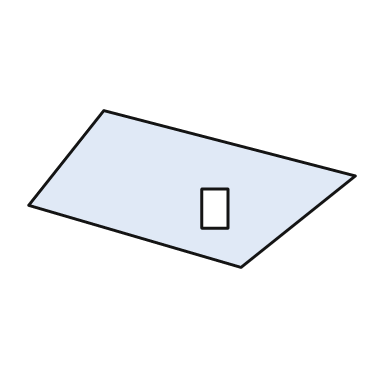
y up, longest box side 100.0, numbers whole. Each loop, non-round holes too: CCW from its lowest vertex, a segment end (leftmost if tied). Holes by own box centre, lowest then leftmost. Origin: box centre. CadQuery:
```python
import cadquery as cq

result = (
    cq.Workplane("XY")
    .moveTo(15.0, -24.0)
    .lineTo(50.0, 4.0)
    .lineTo(-27.0, 24.0)
    .lineTo(-50.0, -5.0)
    .close()
    .moveTo(3.0, -12.0)
    .lineTo(11.0, -12.0)
    .lineTo(11.0, 0.0)
    .lineTo(3.0, 0.0)
    .close()
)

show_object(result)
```